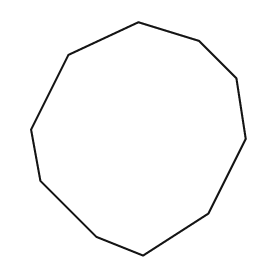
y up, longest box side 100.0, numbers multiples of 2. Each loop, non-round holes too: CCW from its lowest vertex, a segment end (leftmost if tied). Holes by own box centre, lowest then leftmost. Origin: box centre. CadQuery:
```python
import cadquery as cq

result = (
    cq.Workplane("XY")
    .moveTo(2.0, -50.0)
    .lineTo(30.0, -32.0)
    .lineTo(46.0, 0.0)
    .lineTo(42.0, 26.0)
    .lineTo(26.0, 42.0)
    .lineTo(0.0, 50.0)
    .lineTo(-30.0, 36.0)
    .lineTo(-46.0, 4.0)
    .lineTo(-42.0, -18.0)
    .lineTo(-18.0, -42.0)
    .close()
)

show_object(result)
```